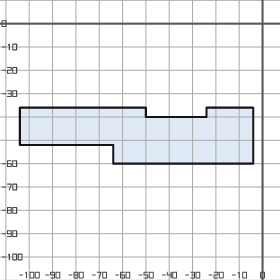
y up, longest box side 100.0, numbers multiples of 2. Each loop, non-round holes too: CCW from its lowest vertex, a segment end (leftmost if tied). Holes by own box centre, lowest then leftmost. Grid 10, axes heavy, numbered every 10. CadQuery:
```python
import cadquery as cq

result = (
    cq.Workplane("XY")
    .moveTo(-64.0, -60.0)
    .lineTo(-4.0, -60.0)
    .lineTo(-4.0, -36.0)
    .lineTo(-24.0, -36.0)
    .lineTo(-24.0, -40.0)
    .lineTo(-50.0, -40.0)
    .lineTo(-50.0, -36.0)
    .lineTo(-104.0, -36.0)
    .lineTo(-104.0, -52.0)
    .lineTo(-64.0, -52.0)
    .close()
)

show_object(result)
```